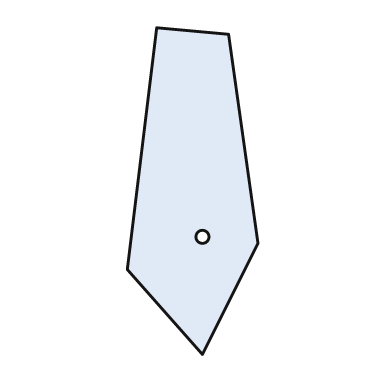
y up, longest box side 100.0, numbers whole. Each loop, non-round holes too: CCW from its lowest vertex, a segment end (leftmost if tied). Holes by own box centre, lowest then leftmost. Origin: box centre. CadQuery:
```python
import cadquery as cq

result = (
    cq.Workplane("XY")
    .moveTo(3.0, -50.0)
    .lineTo(20.0, -16.0)
    .lineTo(11.0, 48.0)
    .lineTo(-11.0, 50.0)
    .lineTo(-20.0, -24.0)
    .close()
    .moveTo(3.0, -14.0)
    .circle(2.0)
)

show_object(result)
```